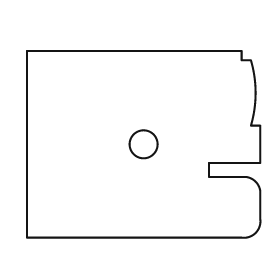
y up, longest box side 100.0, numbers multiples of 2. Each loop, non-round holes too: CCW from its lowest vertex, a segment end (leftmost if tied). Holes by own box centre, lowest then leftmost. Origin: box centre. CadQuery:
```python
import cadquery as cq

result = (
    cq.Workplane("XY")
    .moveTo(-50.0, -40.0)
    .lineTo(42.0, -40.0)
    .threePointArc((48.0, -38.0), (50.0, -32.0))
    .lineTo(50.0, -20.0)
    .threePointArc((48.0, -16.0), (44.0, -14.0))
    .lineTo(28.0, -14.0)
    .lineTo(28.0, -8.0)
    .lineTo(50.0, -8.0)
    .lineTo(50.0, 8.0)
    .lineTo(46.0, 8.0)
    .threePointArc((48.0, 22.0), (46.0, 36.0))
    .lineTo(42.0, 36.0)
    .lineTo(42.0, 40.0)
    .lineTo(-50.0, 40.0)
    .close()
    .moveTo(0.0, 0.0)
    .circle(6.0)
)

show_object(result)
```